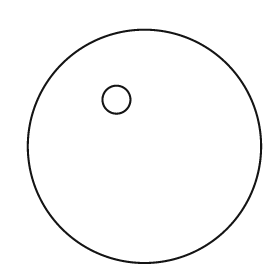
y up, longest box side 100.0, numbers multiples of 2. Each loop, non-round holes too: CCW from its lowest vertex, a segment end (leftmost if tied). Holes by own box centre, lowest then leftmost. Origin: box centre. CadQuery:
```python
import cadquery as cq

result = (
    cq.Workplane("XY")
    .moveTo(0.0, 0.0)
    .circle(50.0)
    .moveTo(-12.0, 20.0)
    .circle(6.0)
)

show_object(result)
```